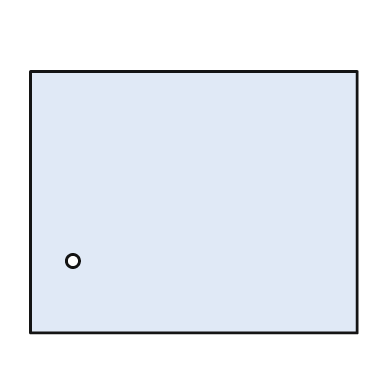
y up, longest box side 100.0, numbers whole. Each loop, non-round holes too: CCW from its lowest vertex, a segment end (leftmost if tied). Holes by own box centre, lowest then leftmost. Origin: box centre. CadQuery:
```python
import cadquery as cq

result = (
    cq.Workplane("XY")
    .moveTo(-50.0, -40.0)
    .lineTo(50.0, -40.0)
    .lineTo(50.0, 40.0)
    .lineTo(-50.0, 40.0)
    .close()
    .moveTo(-37.0, -18.0)
    .circle(2.0)
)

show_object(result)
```